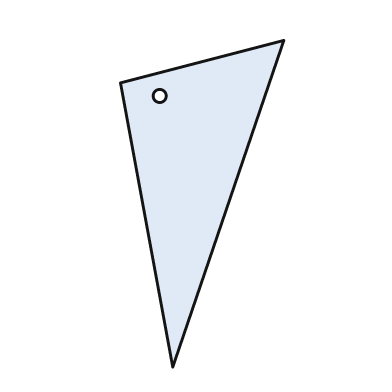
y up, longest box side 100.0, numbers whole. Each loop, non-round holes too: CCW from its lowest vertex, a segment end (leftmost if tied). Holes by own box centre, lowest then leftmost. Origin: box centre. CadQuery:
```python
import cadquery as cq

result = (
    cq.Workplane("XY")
    .moveTo(-9.0, -50.0)
    .lineTo(25.0, 50.0)
    .lineTo(-25.0, 37.0)
    .close()
    .moveTo(-13.0, 33.0)
    .circle(2.0)
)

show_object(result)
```